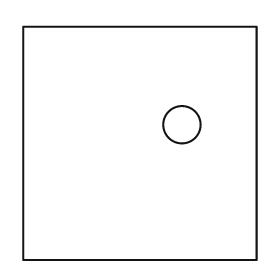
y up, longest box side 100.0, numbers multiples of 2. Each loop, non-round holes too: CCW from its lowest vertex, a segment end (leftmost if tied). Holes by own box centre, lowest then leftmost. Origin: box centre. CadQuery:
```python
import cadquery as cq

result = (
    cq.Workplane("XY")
    .moveTo(-50.0, -50.0)
    .lineTo(50.0, -50.0)
    .lineTo(50.0, 50.0)
    .lineTo(-50.0, 50.0)
    .close()
    .moveTo(18.0, 8.0)
    .circle(8.0)
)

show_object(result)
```